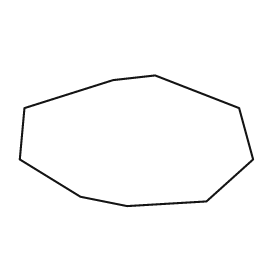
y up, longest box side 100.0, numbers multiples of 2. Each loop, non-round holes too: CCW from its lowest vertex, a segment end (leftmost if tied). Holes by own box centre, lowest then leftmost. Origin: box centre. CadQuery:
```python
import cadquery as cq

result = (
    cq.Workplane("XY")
    .moveTo(-4.0, -28.0)
    .lineTo(30.0, -26.0)
    .lineTo(50.0, -8.0)
    .lineTo(44.0, 14.0)
    .lineTo(8.0, 28.0)
    .lineTo(-10.0, 26.0)
    .lineTo(-48.0, 14.0)
    .lineTo(-50.0, -8.0)
    .lineTo(-24.0, -24.0)
    .close()
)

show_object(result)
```